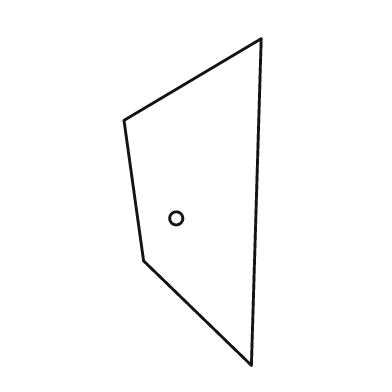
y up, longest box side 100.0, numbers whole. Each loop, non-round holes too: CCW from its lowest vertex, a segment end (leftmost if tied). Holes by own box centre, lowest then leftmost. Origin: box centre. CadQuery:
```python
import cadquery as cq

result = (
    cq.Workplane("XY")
    .moveTo(18.0, -50.0)
    .lineTo(21.0, 50.0)
    .lineTo(-21.0, 25.0)
    .lineTo(-15.0, -18.0)
    .close()
    .moveTo(-5.0, -5.0)
    .circle(2.0)
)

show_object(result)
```